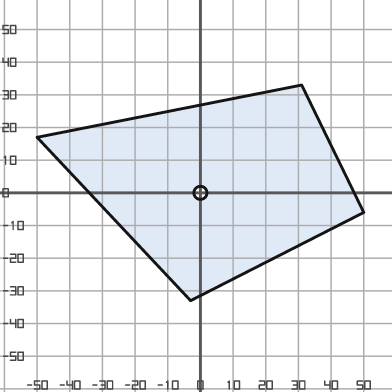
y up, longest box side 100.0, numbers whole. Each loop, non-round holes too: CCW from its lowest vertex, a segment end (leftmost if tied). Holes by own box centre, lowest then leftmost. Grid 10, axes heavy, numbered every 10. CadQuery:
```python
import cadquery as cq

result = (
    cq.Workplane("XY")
    .moveTo(-3.0, -33.0)
    .lineTo(50.0, -6.0)
    .lineTo(31.0, 33.0)
    .lineTo(-50.0, 17.0)
    .close()
    .moveTo(0.0, 0.0)
    .circle(2.0)
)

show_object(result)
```